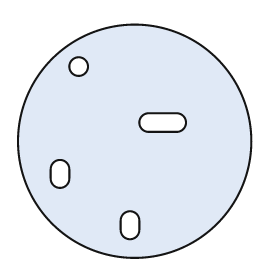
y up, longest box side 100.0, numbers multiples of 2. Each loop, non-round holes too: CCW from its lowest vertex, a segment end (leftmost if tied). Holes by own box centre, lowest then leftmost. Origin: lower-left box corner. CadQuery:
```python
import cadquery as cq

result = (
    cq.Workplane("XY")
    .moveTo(50.0, 50.0)
    .circle(50.0)
    .moveTo(44.0, 12.0)
    .threePointArc((48.0, 8.0), (52.0, 12.0))
    .lineTo(52.0, 16.0)
    .threePointArc((48.0, 20.0), (44.0, 16.0))
    .close()
    .moveTo(14.0, 34.0)
    .threePointArc((18.0, 30.0), (22.0, 34.0))
    .lineTo(22.0, 38.0)
    .threePointArc((18.0, 42.0), (14.0, 38.0))
    .close()
    .moveTo(56.0, 54.0)
    .lineTo(68.0, 54.0)
    .threePointArc((72.0, 58.0), (68.0, 62.0))
    .lineTo(56.0, 62.0)
    .threePointArc((52.0, 58.0), (56.0, 54.0))
    .close()
    .moveTo(26.0, 82.0)
    .circle(4.0)
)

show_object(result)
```